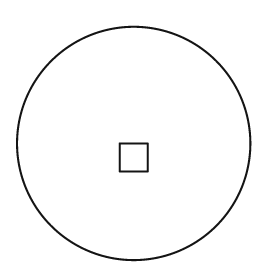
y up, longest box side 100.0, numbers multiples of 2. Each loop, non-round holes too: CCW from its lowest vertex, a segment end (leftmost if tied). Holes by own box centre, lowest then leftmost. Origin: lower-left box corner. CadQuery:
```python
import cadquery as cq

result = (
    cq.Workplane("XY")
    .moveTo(50.0, 50.0)
    .circle(50.0)
    .moveTo(44.0, 38.0)
    .lineTo(56.0, 38.0)
    .lineTo(56.0, 50.0)
    .lineTo(44.0, 50.0)
    .close()
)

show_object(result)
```